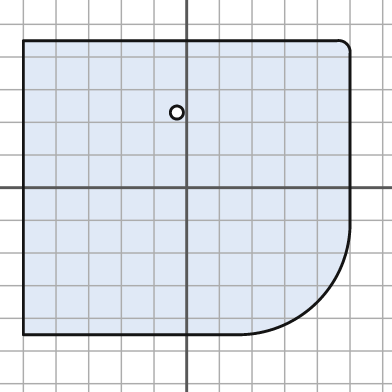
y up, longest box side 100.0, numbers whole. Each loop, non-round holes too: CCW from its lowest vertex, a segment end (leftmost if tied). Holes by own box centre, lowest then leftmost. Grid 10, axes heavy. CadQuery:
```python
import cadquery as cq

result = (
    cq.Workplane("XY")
    .moveTo(-50.0, -45.0)
    .lineTo(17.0, -45.0)
    .threePointArc((40.0, -35.0), (50.0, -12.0))
    .lineTo(50.0, 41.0)
    .threePointArc((49.0, 44.0), (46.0, 45.0))
    .lineTo(-50.0, 45.0)
    .close()
    .moveTo(-3.0, 23.0)
    .circle(2.0)
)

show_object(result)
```